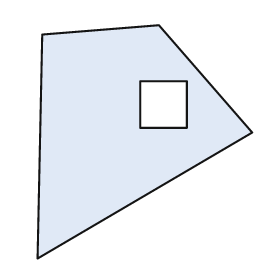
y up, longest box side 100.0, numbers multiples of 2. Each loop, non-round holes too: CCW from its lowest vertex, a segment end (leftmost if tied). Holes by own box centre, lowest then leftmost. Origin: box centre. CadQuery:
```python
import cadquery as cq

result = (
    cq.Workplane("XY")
    .moveTo(-46.0, -50.0)
    .lineTo(46.0, 4.0)
    .lineTo(6.0, 50.0)
    .lineTo(-44.0, 46.0)
    .close()
    .moveTo(-2.0, 6.0)
    .lineTo(18.0, 6.0)
    .lineTo(18.0, 26.0)
    .lineTo(-2.0, 26.0)
    .close()
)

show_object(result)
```